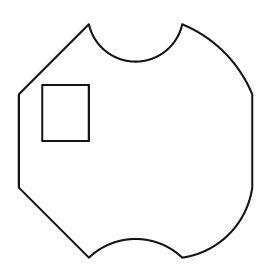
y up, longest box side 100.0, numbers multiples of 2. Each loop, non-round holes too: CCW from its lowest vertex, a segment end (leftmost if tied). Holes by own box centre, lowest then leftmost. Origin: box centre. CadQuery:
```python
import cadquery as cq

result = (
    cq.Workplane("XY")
    .moveTo(-20.0, -50.0)
    .threePointArc((0.0, -42.0), (20.0, -50.0))
    .threePointArc((40.0, -40.0), (50.0, -20.0))
    .lineTo(50.0, 20.0)
    .threePointArc((38.0, 38.0), (20.0, 50.0))
    .threePointArc((0.0, 34.0), (-20.0, 50.0))
    .lineTo(-50.0, 20.0)
    .lineTo(-50.0, -20.0)
    .close()
    .moveTo(-40.0, 0.0)
    .lineTo(-20.0, 0.0)
    .lineTo(-20.0, 24.0)
    .lineTo(-40.0, 24.0)
    .close()
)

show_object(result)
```